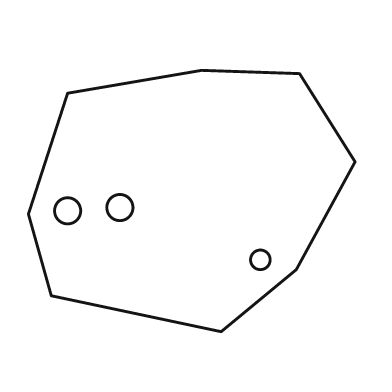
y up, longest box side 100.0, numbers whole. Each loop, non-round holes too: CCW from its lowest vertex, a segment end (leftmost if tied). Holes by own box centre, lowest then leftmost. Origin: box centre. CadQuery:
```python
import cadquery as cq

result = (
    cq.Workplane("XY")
    .moveTo(9.0, -40.0)
    .lineTo(32.0, -21.0)
    .lineTo(50.0, 12.0)
    .lineTo(33.0, 39.0)
    .lineTo(3.0, 40.0)
    .lineTo(-38.0, 33.0)
    .lineTo(-50.0, -4.0)
    .lineTo(-43.0, -29.0)
    .close()
    .moveTo(21.0, -18.0)
    .circle(3.0)
    .moveTo(-38.0, -3.0)
    .circle(4.0)
    .moveTo(-22.0, -2.0)
    .circle(4.0)
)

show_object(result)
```